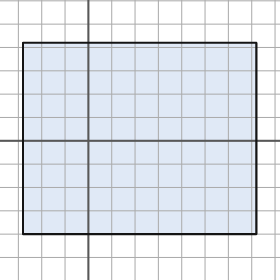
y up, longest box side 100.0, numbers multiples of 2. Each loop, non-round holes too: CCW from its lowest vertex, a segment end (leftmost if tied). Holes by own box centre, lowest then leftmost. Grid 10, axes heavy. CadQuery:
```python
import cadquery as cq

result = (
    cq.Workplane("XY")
    .moveTo(-28.0, -40.0)
    .lineTo(72.0, -40.0)
    .lineTo(72.0, 42.0)
    .lineTo(-28.0, 42.0)
    .close()
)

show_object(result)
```